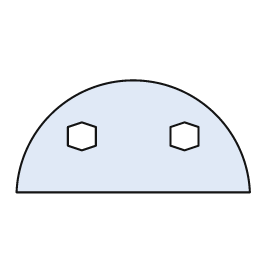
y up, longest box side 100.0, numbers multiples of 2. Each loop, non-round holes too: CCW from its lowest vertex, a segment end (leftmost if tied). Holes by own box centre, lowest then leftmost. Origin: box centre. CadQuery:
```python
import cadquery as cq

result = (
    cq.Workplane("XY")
    .moveTo(-50.0, -24.0)
    .lineTo(50.0, -24.0)
    .threePointArc((0.0, 24.0), (-50.0, -24.0))
    .close()
    .moveTo(-22.0, -6.0)
    .lineTo(-16.0, -4.0)
    .lineTo(-16.0, 4.0)
    .lineTo(-22.0, 6.0)
    .lineTo(-28.0, 4.0)
    .lineTo(-28.0, -4.0)
    .close()
    .moveTo(22.0, -6.0)
    .lineTo(28.0, -4.0)
    .lineTo(28.0, 4.0)
    .lineTo(22.0, 6.0)
    .lineTo(16.0, 4.0)
    .lineTo(16.0, -4.0)
    .close()
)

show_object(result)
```